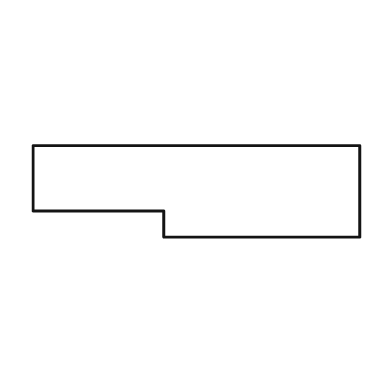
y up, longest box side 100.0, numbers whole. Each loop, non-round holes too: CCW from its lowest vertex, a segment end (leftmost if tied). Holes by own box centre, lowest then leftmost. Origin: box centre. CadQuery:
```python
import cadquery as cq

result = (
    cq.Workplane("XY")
    .moveTo(-10.0, -14.0)
    .lineTo(50.0, -14.0)
    .lineTo(50.0, 14.0)
    .lineTo(-50.0, 14.0)
    .lineTo(-50.0, -6.0)
    .lineTo(-10.0, -6.0)
    .close()
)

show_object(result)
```